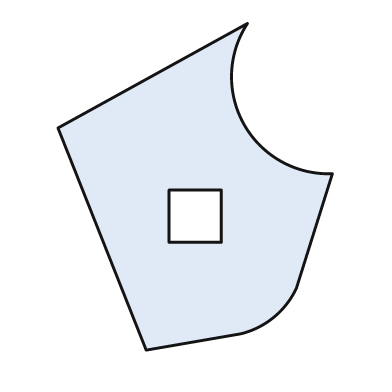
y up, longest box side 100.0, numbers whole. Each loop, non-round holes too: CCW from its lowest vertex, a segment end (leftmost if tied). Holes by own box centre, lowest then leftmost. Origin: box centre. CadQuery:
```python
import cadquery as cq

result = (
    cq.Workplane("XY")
    .moveTo(-15.0, -50.0)
    .lineTo(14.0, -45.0)
    .threePointArc((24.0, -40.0), (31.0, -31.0))
    .lineTo(42.0, 4.0)
    .threePointArc((15.0, 19.0), (16.0, 50.0))
    .lineTo(-42.0, 18.0)
    .close()
    .moveTo(-8.0, -17.0)
    .lineTo(8.0, -17.0)
    .lineTo(8.0, -1.0)
    .lineTo(-8.0, -1.0)
    .close()
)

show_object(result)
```